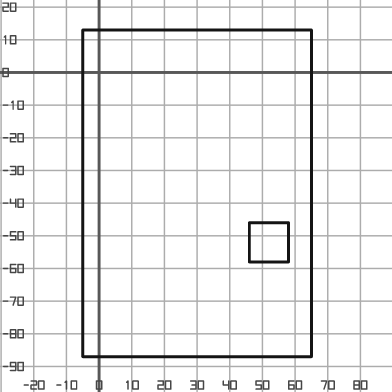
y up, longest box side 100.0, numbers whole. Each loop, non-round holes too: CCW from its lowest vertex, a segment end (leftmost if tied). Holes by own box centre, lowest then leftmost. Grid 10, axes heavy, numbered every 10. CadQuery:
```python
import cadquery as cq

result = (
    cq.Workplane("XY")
    .moveTo(-5.0, -87.0)
    .lineTo(65.0, -87.0)
    .lineTo(65.0, 13.0)
    .lineTo(-5.0, 13.0)
    .close()
    .moveTo(46.0, -58.0)
    .lineTo(58.0, -58.0)
    .lineTo(58.0, -46.0)
    .lineTo(46.0, -46.0)
    .close()
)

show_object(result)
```